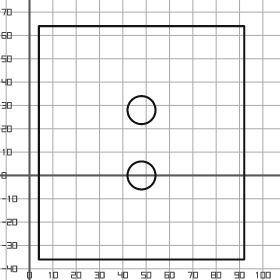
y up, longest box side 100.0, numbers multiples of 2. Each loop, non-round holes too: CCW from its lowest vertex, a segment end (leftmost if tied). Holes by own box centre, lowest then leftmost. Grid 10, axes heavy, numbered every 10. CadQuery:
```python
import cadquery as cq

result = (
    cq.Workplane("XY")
    .moveTo(4.0, -36.0)
    .lineTo(92.0, -36.0)
    .lineTo(92.0, 64.0)
    .lineTo(4.0, 64.0)
    .close()
    .moveTo(48.0, 0.0)
    .circle(6.0)
    .moveTo(48.0, 28.0)
    .circle(6.0)
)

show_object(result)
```